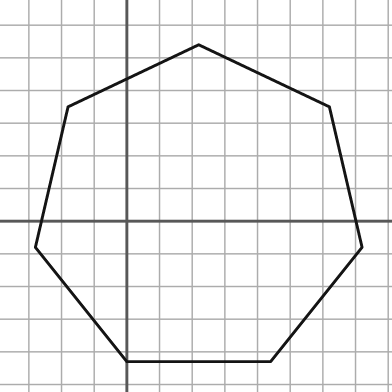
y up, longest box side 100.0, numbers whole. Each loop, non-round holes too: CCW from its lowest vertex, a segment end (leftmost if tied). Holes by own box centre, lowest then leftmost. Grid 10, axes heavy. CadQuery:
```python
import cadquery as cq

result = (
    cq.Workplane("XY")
    .moveTo(0.0, -43.0)
    .lineTo(44.0, -43.0)
    .lineTo(72.0, -8.0)
    .lineTo(62.0, 35.0)
    .lineTo(22.0, 54.0)
    .lineTo(-18.0, 35.0)
    .lineTo(-28.0, -8.0)
    .close()
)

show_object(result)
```